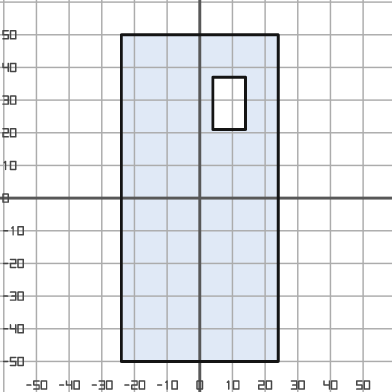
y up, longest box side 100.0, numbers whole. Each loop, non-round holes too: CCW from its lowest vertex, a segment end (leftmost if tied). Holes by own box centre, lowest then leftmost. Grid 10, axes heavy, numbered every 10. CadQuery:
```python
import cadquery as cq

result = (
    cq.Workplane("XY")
    .moveTo(-24.0, -50.0)
    .lineTo(24.0, -50.0)
    .lineTo(24.0, 50.0)
    .lineTo(-24.0, 50.0)
    .close()
    .moveTo(4.0, 21.0)
    .lineTo(14.0, 21.0)
    .lineTo(14.0, 37.0)
    .lineTo(4.0, 37.0)
    .close()
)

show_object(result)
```